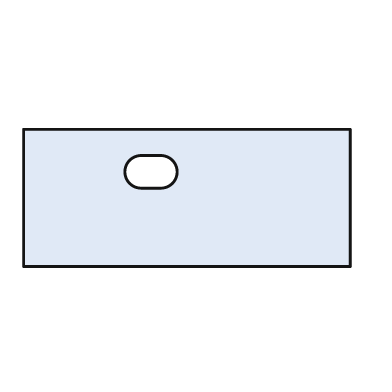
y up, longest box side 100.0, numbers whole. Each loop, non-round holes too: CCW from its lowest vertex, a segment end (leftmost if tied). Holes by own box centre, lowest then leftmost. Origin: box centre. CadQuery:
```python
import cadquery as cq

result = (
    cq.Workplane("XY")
    .moveTo(-50.0, -21.0)
    .lineTo(50.0, -21.0)
    .lineTo(50.0, 21.0)
    .lineTo(-50.0, 21.0)
    .close()
    .moveTo(-14.0, 3.0)
    .lineTo(-8.0, 3.0)
    .threePointArc((-3.0, 8.0), (-8.0, 13.0))
    .lineTo(-14.0, 13.0)
    .threePointArc((-19.0, 8.0), (-14.0, 3.0))
    .close()
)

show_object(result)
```